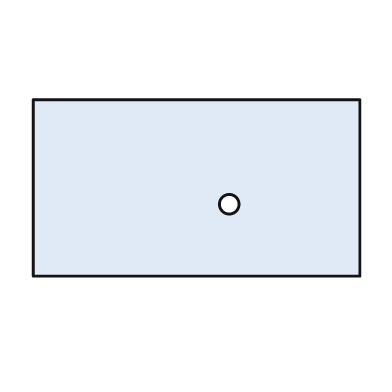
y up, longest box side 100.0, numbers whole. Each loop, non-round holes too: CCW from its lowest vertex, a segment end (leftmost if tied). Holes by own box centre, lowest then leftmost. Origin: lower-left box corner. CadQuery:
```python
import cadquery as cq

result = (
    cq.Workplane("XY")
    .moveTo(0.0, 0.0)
    .lineTo(100.0, 0.0)
    .lineTo(100.0, 54.0)
    .lineTo(0.0, 54.0)
    .close()
    .moveTo(60.0, 22.0)
    .circle(3.0)
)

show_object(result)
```